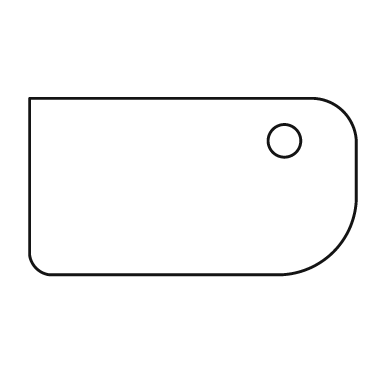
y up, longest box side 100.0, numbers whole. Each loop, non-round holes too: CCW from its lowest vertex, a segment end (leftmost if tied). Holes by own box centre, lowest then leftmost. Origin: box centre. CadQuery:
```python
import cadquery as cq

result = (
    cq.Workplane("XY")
    .moveTo(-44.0, -27.0)
    .lineTo(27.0, -27.0)
    .threePointArc((43.0, -20.0), (50.0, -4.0))
    .lineTo(50.0, 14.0)
    .threePointArc((46.0, 23.0), (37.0, 27.0))
    .lineTo(-50.0, 27.0)
    .lineTo(-50.0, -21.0)
    .threePointArc((-48.0, -25.0), (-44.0, -27.0))
    .close()
    .moveTo(28.0, 14.0)
    .circle(5.0)
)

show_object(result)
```